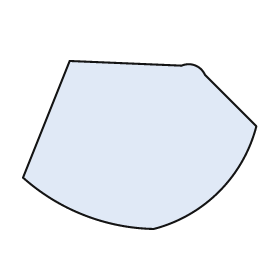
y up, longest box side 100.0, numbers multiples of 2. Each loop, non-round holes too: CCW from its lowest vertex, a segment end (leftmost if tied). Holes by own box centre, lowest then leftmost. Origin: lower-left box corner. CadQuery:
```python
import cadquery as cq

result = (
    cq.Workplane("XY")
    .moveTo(56.0, 0.0)
    .threePointArc((84.0, 16.0), (100.0, 44.0))
    .lineTo(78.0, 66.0)
    .threePointArc((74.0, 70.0), (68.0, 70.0))
    .lineTo(20.0, 72.0)
    .lineTo(0.0, 22.0)
    .threePointArc((26.0, 6.0), (56.0, 0.0))
    .close()
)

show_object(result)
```